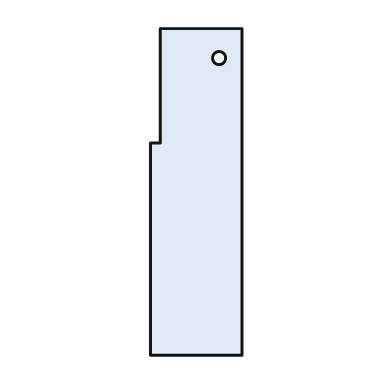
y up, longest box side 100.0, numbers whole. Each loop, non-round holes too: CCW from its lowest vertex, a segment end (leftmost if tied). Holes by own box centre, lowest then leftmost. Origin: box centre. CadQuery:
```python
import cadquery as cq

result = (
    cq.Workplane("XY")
    .moveTo(-14.0, -50.0)
    .lineTo(14.0, -50.0)
    .lineTo(14.0, 50.0)
    .lineTo(-11.0, 50.0)
    .lineTo(-11.0, 15.0)
    .lineTo(-14.0, 15.0)
    .close()
    .moveTo(7.0, 41.0)
    .circle(2.0)
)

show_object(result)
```